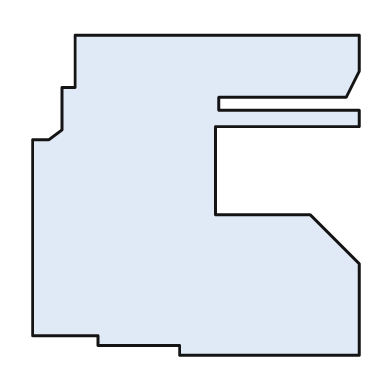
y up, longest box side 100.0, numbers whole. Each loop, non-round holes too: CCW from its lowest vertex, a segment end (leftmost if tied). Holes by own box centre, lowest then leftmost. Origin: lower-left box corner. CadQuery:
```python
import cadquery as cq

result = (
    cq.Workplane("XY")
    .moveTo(45.0, 0.0)
    .lineTo(100.0, 0.0)
    .lineTo(100.0, 28.0)
    .lineTo(85.0, 43.0)
    .lineTo(56.0, 43.0)
    .lineTo(56.0, 70.0)
    .lineTo(100.0, 70.0)
    .lineTo(100.0, 75.0)
    .lineTo(57.0, 75.0)
    .lineTo(57.0, 79.0)
    .lineTo(96.0, 79.0)
    .lineTo(100.0, 87.0)
    .lineTo(100.0, 98.0)
    .lineTo(13.0, 98.0)
    .lineTo(13.0, 82.0)
    .lineTo(9.0, 82.0)
    .lineTo(9.0, 69.0)
    .lineTo(5.0, 66.0)
    .lineTo(0.0, 66.0)
    .lineTo(0.0, 6.0)
    .lineTo(20.0, 6.0)
    .lineTo(20.0, 3.0)
    .lineTo(45.0, 3.0)
    .close()
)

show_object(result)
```